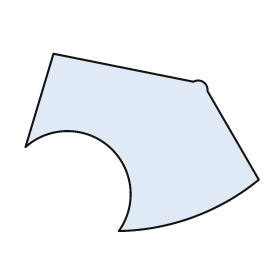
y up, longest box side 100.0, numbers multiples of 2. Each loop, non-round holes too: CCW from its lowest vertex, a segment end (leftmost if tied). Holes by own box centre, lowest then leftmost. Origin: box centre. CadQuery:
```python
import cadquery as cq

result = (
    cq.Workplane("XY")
    .moveTo(-10.0, -38.0)
    .threePointArc((22.0, -32.0), (50.0, -16.0))
    .lineTo(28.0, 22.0)
    .threePointArc((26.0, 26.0), (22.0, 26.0))
    .lineTo(-38.0, 38.0)
    .lineTo(-50.0, -2.0)
    .threePointArc((-14.0, -2.0), (-10.0, -38.0))
    .close()
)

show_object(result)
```